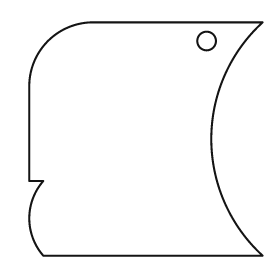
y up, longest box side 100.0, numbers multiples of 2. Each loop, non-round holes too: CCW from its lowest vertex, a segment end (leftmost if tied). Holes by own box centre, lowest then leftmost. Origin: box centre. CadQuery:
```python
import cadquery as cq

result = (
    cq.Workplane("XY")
    .moveTo(-44.0, -50.0)
    .lineTo(50.0, -50.0)
    .threePointArc((28.0, 0.0), (50.0, 50.0))
    .lineTo(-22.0, 50.0)
    .threePointArc((-42.0, 42.0), (-50.0, 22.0))
    .lineTo(-50.0, -18.0)
    .lineTo(-44.0, -18.0)
    .threePointArc((-50.0, -34.0), (-44.0, -50.0))
    .close()
    .moveTo(26.0, 42.0)
    .circle(4.0)
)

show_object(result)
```